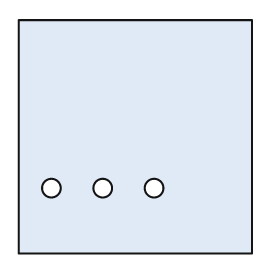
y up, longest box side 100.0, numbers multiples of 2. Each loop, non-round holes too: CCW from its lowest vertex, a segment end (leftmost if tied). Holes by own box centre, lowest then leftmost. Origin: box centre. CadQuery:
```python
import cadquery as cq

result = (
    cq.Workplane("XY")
    .moveTo(-50.0, -50.0)
    .lineTo(50.0, -50.0)
    .lineTo(50.0, 50.0)
    .lineTo(-50.0, 50.0)
    .close()
    .moveTo(-36.0, -22.0)
    .circle(4.0)
    .moveTo(-14.0, -22.0)
    .circle(4.0)
    .moveTo(8.0, -22.0)
    .circle(4.0)
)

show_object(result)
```